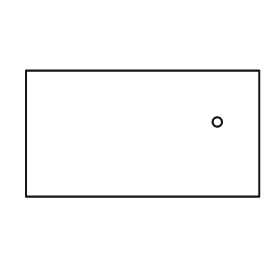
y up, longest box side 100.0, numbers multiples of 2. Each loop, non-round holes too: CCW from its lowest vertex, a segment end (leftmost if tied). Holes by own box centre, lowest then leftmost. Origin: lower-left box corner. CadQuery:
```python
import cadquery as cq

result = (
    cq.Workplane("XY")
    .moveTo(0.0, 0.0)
    .lineTo(100.0, 0.0)
    .lineTo(100.0, 54.0)
    .lineTo(0.0, 54.0)
    .close()
    .moveTo(82.0, 32.0)
    .circle(2.0)
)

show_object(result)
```